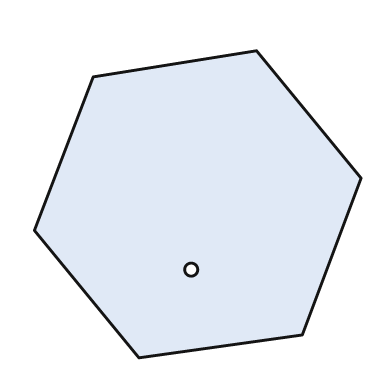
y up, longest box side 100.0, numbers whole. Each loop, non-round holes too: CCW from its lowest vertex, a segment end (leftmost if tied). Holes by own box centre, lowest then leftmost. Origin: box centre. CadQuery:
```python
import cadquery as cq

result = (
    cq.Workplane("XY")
    .moveTo(-18.0, -47.0)
    .lineTo(32.0, -40.0)
    .lineTo(50.0, 8.0)
    .lineTo(18.0, 47.0)
    .lineTo(-32.0, 39.0)
    .lineTo(-50.0, -8.0)
    .close()
    .moveTo(-2.0, -20.0)
    .circle(2.0)
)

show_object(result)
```